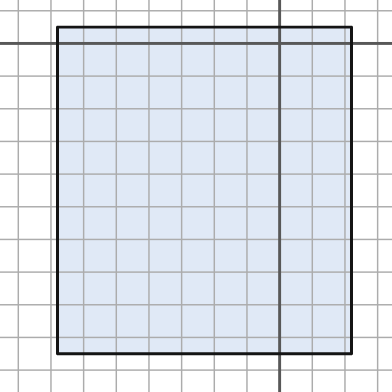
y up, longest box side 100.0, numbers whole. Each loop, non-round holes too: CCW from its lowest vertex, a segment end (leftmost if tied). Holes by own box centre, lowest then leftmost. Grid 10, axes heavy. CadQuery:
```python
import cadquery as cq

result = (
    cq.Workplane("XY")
    .moveTo(-68.0, -95.0)
    .lineTo(22.0, -95.0)
    .lineTo(22.0, 5.0)
    .lineTo(-68.0, 5.0)
    .close()
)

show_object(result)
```